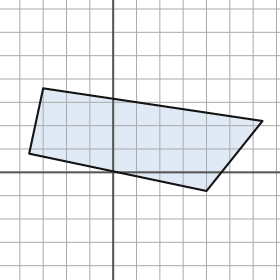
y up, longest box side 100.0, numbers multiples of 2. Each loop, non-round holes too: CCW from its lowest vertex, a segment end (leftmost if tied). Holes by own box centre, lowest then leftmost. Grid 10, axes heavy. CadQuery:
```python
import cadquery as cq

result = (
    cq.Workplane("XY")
    .moveTo(40.0, -8.0)
    .lineTo(64.0, 22.0)
    .lineTo(-30.0, 36.0)
    .lineTo(-36.0, 8.0)
    .close()
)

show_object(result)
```